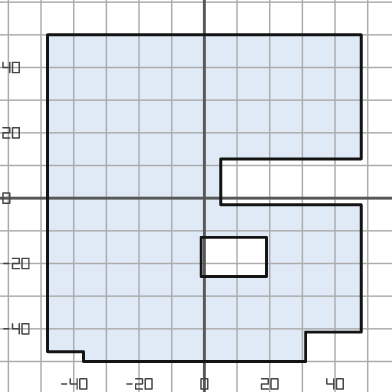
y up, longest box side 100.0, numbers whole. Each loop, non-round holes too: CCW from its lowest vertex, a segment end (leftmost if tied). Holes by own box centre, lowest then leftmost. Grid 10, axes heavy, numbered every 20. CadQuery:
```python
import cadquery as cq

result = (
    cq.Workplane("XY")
    .moveTo(-37.0, -50.0)
    .lineTo(31.0, -50.0)
    .lineTo(31.0, -41.0)
    .lineTo(48.0, -41.0)
    .lineTo(48.0, -2.0)
    .lineTo(5.0, -2.0)
    .lineTo(5.0, 12.0)
    .lineTo(48.0, 12.0)
    .lineTo(48.0, 50.0)
    .lineTo(-48.0, 50.0)
    .lineTo(-48.0, -47.0)
    .lineTo(-37.0, -47.0)
    .close()
    .moveTo(-1.0, -24.0)
    .lineTo(19.0, -24.0)
    .lineTo(19.0, -12.0)
    .lineTo(-1.0, -12.0)
    .close()
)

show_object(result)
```